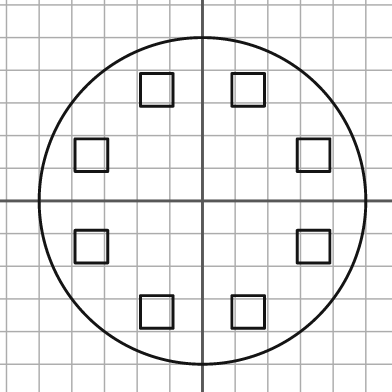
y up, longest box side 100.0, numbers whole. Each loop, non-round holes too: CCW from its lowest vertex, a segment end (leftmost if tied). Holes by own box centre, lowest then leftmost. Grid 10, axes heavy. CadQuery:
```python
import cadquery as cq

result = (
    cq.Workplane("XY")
    .moveTo(0.0, 0.0)
    .circle(50.0)
    .moveTo(-19.0, -39.0)
    .lineTo(-9.0, -39.0)
    .lineTo(-9.0, -29.0)
    .lineTo(-19.0, -29.0)
    .close()
    .moveTo(9.0, -39.0)
    .lineTo(19.0, -39.0)
    .lineTo(19.0, -29.0)
    .lineTo(9.0, -29.0)
    .close()
    .moveTo(-39.0, -19.0)
    .lineTo(-29.0, -19.0)
    .lineTo(-29.0, -9.0)
    .lineTo(-39.0, -9.0)
    .close()
    .moveTo(29.0, -19.0)
    .lineTo(39.0, -19.0)
    .lineTo(39.0, -9.0)
    .lineTo(29.0, -9.0)
    .close()
    .moveTo(-39.0, 9.0)
    .lineTo(-29.0, 9.0)
    .lineTo(-29.0, 19.0)
    .lineTo(-39.0, 19.0)
    .close()
    .moveTo(29.0, 9.0)
    .lineTo(39.0, 9.0)
    .lineTo(39.0, 19.0)
    .lineTo(29.0, 19.0)
    .close()
    .moveTo(-19.0, 29.0)
    .lineTo(-9.0, 29.0)
    .lineTo(-9.0, 39.0)
    .lineTo(-19.0, 39.0)
    .close()
    .moveTo(9.0, 29.0)
    .lineTo(19.0, 29.0)
    .lineTo(19.0, 39.0)
    .lineTo(9.0, 39.0)
    .close()
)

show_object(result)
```